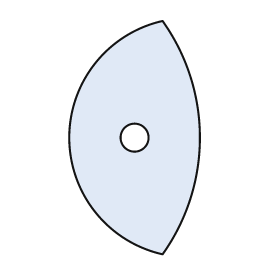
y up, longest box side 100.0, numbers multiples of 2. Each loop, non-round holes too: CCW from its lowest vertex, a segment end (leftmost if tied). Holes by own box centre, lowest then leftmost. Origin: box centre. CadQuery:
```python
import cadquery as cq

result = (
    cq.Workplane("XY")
    .moveTo(12.0, -50.0)
    .threePointArc((28.0, 0.0), (12.0, 50.0))
    .threePointArc((-28.0, 0.0), (12.0, -50.0))
    .close()
    .moveTo(0.0, 0.0)
    .circle(6.0)
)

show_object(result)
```